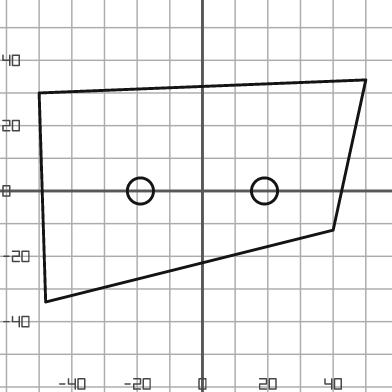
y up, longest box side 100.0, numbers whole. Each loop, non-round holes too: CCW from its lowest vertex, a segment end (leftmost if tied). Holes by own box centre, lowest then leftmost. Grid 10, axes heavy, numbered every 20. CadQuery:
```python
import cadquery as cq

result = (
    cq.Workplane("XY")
    .moveTo(-48.0, -34.0)
    .lineTo(40.0, -12.0)
    .lineTo(50.0, 34.0)
    .lineTo(-50.0, 30.0)
    .close()
    .moveTo(-19.0, 0.0)
    .circle(4.0)
    .moveTo(19.0, 0.0)
    .circle(4.0)
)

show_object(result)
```